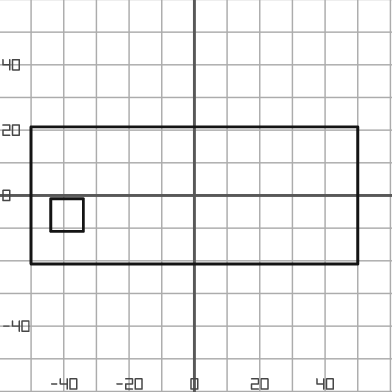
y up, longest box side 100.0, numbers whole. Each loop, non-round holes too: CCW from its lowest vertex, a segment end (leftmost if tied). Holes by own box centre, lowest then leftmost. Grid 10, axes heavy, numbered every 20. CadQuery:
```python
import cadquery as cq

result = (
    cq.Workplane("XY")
    .moveTo(-50.0, -21.0)
    .lineTo(50.0, -21.0)
    .lineTo(50.0, 21.0)
    .lineTo(-50.0, 21.0)
    .close()
    .moveTo(-44.0, -11.0)
    .lineTo(-34.0, -11.0)
    .lineTo(-34.0, -1.0)
    .lineTo(-44.0, -1.0)
    .close()
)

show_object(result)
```